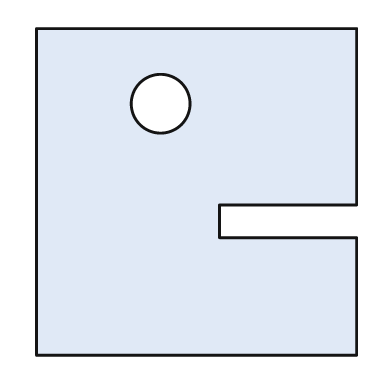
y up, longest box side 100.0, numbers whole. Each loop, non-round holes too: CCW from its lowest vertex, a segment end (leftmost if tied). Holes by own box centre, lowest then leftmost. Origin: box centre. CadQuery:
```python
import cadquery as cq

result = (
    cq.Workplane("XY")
    .moveTo(-49.0, -50.0)
    .lineTo(49.0, -50.0)
    .lineTo(49.0, -14.0)
    .lineTo(7.0, -14.0)
    .lineTo(7.0, -4.0)
    .lineTo(49.0, -4.0)
    .lineTo(49.0, 50.0)
    .lineTo(-49.0, 50.0)
    .close()
    .moveTo(-11.0, 27.0)
    .circle(9.0)
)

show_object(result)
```